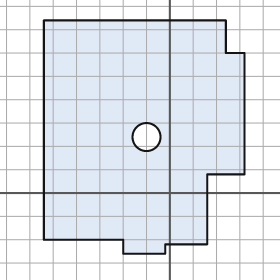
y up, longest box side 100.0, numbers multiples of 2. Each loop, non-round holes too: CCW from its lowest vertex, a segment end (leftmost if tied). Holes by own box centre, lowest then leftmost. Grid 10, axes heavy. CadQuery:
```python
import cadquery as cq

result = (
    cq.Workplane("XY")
    .moveTo(-20.0, -26.0)
    .lineTo(-2.0, -26.0)
    .lineTo(-2.0, -22.0)
    .lineTo(16.0, -22.0)
    .lineTo(16.0, 8.0)
    .lineTo(32.0, 8.0)
    .lineTo(32.0, 60.0)
    .lineTo(24.0, 60.0)
    .lineTo(24.0, 74.0)
    .lineTo(-54.0, 74.0)
    .lineTo(-54.0, -20.0)
    .lineTo(-20.0, -20.0)
    .close()
    .moveTo(-10.0, 24.0)
    .circle(6.0)
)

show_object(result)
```